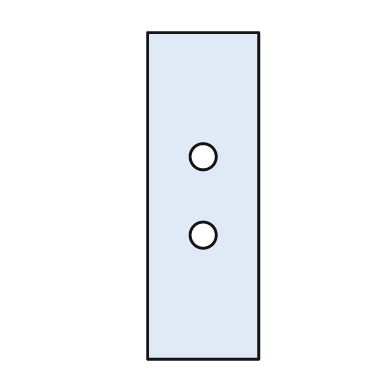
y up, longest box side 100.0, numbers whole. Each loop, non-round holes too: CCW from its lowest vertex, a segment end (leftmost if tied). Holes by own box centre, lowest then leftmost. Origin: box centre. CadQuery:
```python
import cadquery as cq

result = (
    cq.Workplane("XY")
    .moveTo(-17.0, -50.0)
    .lineTo(17.0, -50.0)
    .lineTo(17.0, 50.0)
    .lineTo(-17.0, 50.0)
    .close()
    .moveTo(0.0, -12.0)
    .circle(4.0)
    .moveTo(0.0, 12.0)
    .circle(4.0)
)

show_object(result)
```